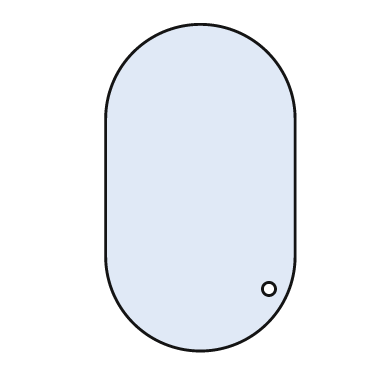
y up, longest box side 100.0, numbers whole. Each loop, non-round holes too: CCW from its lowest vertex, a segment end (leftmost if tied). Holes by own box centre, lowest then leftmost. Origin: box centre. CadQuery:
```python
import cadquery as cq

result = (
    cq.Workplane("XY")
    .moveTo(-29.0, -21.0)
    .threePointArc((0.0, -50.0), (29.0, -21.0))
    .lineTo(29.0, 21.0)
    .threePointArc((0.0, 50.0), (-29.0, 21.0))
    .close()
    .moveTo(21.0, -31.0)
    .circle(2.0)
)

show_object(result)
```